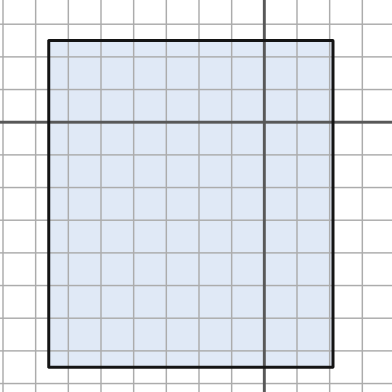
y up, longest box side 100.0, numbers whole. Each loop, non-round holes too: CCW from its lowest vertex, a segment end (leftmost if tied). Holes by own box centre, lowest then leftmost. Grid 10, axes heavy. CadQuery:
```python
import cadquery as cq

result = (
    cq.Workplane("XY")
    .moveTo(-66.0, -75.0)
    .lineTo(21.0, -75.0)
    .lineTo(21.0, 25.0)
    .lineTo(-66.0, 25.0)
    .close()
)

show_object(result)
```